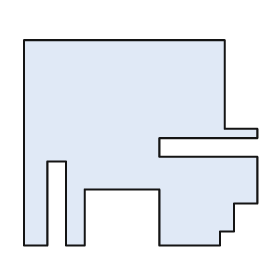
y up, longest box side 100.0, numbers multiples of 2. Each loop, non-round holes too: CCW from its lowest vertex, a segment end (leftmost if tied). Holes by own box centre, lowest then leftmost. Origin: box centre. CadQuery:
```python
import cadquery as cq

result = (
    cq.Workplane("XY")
    .moveTo(-50.0, -44.0)
    .lineTo(-40.0, -44.0)
    .lineTo(-40.0, -8.0)
    .lineTo(-32.0, -8.0)
    .lineTo(-32.0, -44.0)
    .lineTo(-24.0, -44.0)
    .lineTo(-24.0, -20.0)
    .lineTo(8.0, -20.0)
    .lineTo(8.0, -44.0)
    .lineTo(34.0, -44.0)
    .lineTo(34.0, -38.0)
    .lineTo(40.0, -38.0)
    .lineTo(40.0, -26.0)
    .lineTo(50.0, -26.0)
    .lineTo(50.0, -6.0)
    .lineTo(8.0, -6.0)
    .lineTo(8.0, 2.0)
    .lineTo(50.0, 2.0)
    .lineTo(50.0, 6.0)
    .lineTo(36.0, 6.0)
    .lineTo(36.0, 44.0)
    .lineTo(-50.0, 44.0)
    .close()
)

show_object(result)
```